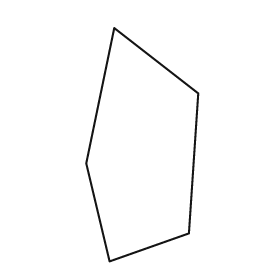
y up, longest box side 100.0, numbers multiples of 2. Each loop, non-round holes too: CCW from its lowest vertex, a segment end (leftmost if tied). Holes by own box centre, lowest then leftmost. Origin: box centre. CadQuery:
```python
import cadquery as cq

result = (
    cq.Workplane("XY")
    .moveTo(-14.0, -50.0)
    .lineTo(20.0, -38.0)
    .lineTo(24.0, 22.0)
    .lineTo(-12.0, 50.0)
    .lineTo(-24.0, -8.0)
    .close()
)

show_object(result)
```